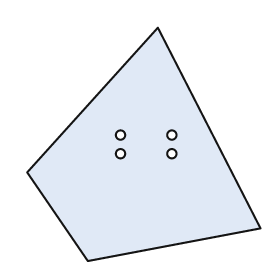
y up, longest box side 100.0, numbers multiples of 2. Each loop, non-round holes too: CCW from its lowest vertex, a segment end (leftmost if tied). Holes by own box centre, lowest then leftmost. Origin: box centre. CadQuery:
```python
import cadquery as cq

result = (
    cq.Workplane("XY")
    .moveTo(-24.0, -50.0)
    .lineTo(50.0, -36.0)
    .lineTo(6.0, 50.0)
    .lineTo(-50.0, -12.0)
    .close()
    .moveTo(-10.0, -4.0)
    .circle(2.0)
    .moveTo(12.0, -4.0)
    .circle(2.0)
    .moveTo(-10.0, 4.0)
    .circle(2.0)
    .moveTo(12.0, 4.0)
    .circle(2.0)
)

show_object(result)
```